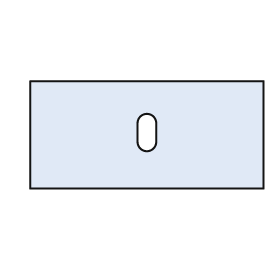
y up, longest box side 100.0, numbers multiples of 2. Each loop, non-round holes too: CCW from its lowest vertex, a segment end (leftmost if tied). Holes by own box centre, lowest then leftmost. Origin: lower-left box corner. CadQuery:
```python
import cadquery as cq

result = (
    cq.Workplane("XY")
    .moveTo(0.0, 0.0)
    .lineTo(100.0, 0.0)
    .lineTo(100.0, 46.0)
    .lineTo(0.0, 46.0)
    .close()
    .moveTo(46.0, 20.0)
    .threePointArc((50.0, 16.0), (54.0, 20.0))
    .lineTo(54.0, 28.0)
    .threePointArc((50.0, 32.0), (46.0, 28.0))
    .close()
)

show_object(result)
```